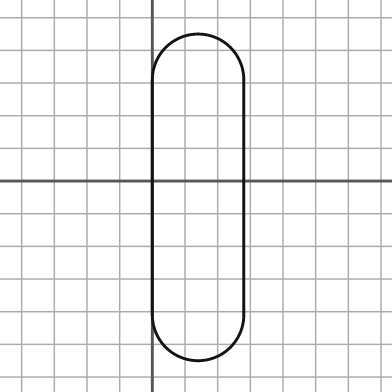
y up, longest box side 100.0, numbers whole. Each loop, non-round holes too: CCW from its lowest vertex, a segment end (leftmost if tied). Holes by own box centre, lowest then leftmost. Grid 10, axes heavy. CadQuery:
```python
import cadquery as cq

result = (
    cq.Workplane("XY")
    .moveTo(0.0, -41.0)
    .threePointArc((14.0, -55.0), (28.0, -41.0))
    .lineTo(28.0, 31.0)
    .threePointArc((14.0, 45.0), (0.0, 31.0))
    .close()
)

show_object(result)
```